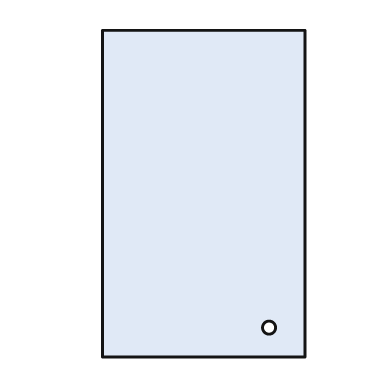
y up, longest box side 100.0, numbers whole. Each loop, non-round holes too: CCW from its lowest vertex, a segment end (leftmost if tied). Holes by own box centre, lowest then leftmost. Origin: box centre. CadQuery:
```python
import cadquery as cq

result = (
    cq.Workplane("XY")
    .moveTo(-31.0, -50.0)
    .lineTo(31.0, -50.0)
    .lineTo(31.0, 50.0)
    .lineTo(-31.0, 50.0)
    .close()
    .moveTo(20.0, -41.0)
    .circle(2.0)
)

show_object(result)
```